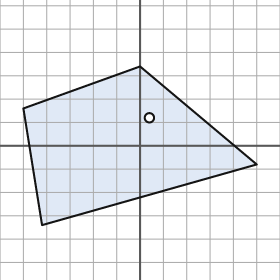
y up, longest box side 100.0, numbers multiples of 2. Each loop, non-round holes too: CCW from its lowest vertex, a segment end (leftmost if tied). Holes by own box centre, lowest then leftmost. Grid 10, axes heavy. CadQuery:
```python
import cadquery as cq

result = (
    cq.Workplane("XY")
    .moveTo(-42.0, -34.0)
    .lineTo(50.0, -8.0)
    .lineTo(0.0, 34.0)
    .lineTo(-50.0, 16.0)
    .close()
    .moveTo(4.0, 12.0)
    .circle(2.0)
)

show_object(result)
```